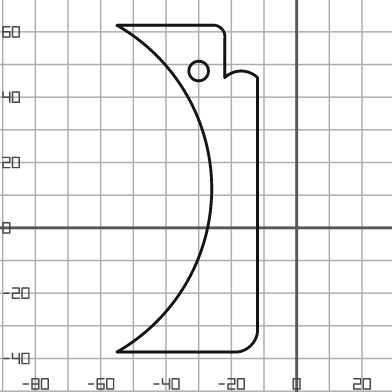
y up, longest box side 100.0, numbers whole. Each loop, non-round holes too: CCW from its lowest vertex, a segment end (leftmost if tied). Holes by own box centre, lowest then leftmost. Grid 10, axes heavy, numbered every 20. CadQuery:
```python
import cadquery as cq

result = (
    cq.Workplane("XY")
    .moveTo(-55.0, -38.0)
    .lineTo(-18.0, -38.0)
    .threePointArc((-14.0, -36.0), (-12.0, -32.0))
    .lineTo(-12.0, 46.0)
    .threePointArc((-17.0, 48.0), (-22.0, 46.0))
    .lineTo(-22.0, 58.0)
    .threePointArc((-23.0, 61.0), (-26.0, 62.0))
    .lineTo(-55.0, 62.0)
    .threePointArc((-26.0, 12.0), (-55.0, -38.0))
    .close()
    .moveTo(-30.0, 48.0)
    .circle(3.0)
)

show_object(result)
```